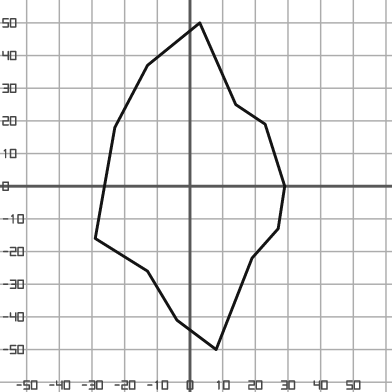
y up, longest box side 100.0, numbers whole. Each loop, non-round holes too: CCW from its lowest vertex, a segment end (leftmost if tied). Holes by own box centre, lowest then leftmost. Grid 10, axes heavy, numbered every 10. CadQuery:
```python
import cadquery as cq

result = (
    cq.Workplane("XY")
    .moveTo(8.0, -50.0)
    .lineTo(19.0, -22.0)
    .lineTo(27.0, -13.0)
    .lineTo(29.0, 0.0)
    .lineTo(23.0, 19.0)
    .lineTo(14.0, 25.0)
    .lineTo(3.0, 50.0)
    .lineTo(-13.0, 37.0)
    .lineTo(-23.0, 18.0)
    .lineTo(-29.0, -16.0)
    .lineTo(-13.0, -26.0)
    .lineTo(-4.0, -41.0)
    .close()
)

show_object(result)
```